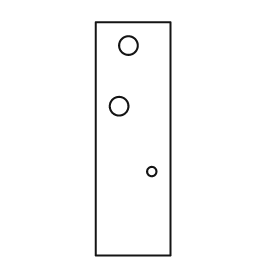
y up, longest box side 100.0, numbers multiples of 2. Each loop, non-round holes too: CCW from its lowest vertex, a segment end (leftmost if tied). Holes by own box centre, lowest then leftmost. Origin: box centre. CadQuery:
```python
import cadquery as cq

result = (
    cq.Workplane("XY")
    .moveTo(-16.0, -50.0)
    .lineTo(16.0, -50.0)
    .lineTo(16.0, 50.0)
    .lineTo(-16.0, 50.0)
    .close()
    .moveTo(8.0, -14.0)
    .circle(2.0)
    .moveTo(-6.0, 14.0)
    .circle(4.0)
    .moveTo(-2.0, 40.0)
    .circle(4.0)
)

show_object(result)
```